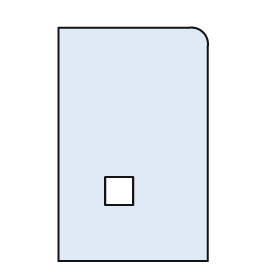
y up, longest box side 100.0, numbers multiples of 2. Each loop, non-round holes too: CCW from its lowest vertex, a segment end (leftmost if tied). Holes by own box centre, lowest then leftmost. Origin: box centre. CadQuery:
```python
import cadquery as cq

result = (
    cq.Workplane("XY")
    .moveTo(-32.0, -50.0)
    .lineTo(32.0, -50.0)
    .lineTo(32.0, 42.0)
    .threePointArc((30.0, 48.0), (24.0, 50.0))
    .lineTo(-32.0, 50.0)
    .close()
    .moveTo(-12.0, -26.0)
    .lineTo(0.0, -26.0)
    .lineTo(0.0, -14.0)
    .lineTo(-12.0, -14.0)
    .close()
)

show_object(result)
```